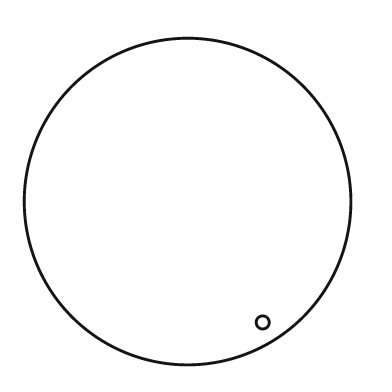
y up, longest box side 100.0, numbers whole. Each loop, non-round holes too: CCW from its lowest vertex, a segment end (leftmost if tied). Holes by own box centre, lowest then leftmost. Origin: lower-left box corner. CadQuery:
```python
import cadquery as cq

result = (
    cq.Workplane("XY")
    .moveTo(50.0, 50.0)
    .circle(50.0)
    .moveTo(73.0, 13.0)
    .circle(2.0)
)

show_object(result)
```